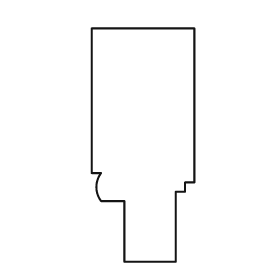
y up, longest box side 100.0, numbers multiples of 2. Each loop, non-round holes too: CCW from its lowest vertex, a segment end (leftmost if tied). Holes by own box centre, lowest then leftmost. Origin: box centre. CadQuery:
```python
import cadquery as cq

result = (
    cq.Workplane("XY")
    .moveTo(-8.0, -50.0)
    .lineTo(14.0, -50.0)
    .lineTo(14.0, -20.0)
    .lineTo(18.0, -20.0)
    .lineTo(18.0, -16.0)
    .lineTo(22.0, -16.0)
    .lineTo(22.0, 50.0)
    .lineTo(-22.0, 50.0)
    .lineTo(-22.0, -12.0)
    .lineTo(-18.0, -12.0)
    .threePointArc((-20.0, -18.0), (-18.0, -24.0))
    .lineTo(-8.0, -24.0)
    .close()
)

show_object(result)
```